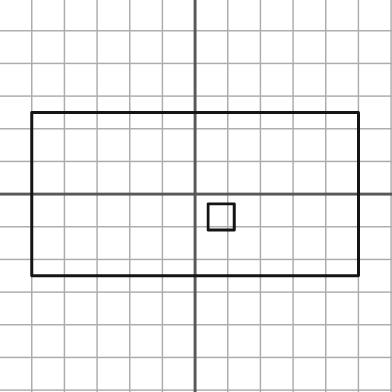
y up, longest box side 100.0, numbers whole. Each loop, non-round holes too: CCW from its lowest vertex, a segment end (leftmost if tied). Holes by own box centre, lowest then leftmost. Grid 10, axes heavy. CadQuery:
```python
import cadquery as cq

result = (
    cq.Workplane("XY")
    .moveTo(-50.0, -25.0)
    .lineTo(50.0, -25.0)
    .lineTo(50.0, 25.0)
    .lineTo(-50.0, 25.0)
    .close()
    .moveTo(4.0, -11.0)
    .lineTo(12.0, -11.0)
    .lineTo(12.0, -3.0)
    .lineTo(4.0, -3.0)
    .close()
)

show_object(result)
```